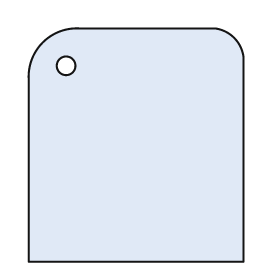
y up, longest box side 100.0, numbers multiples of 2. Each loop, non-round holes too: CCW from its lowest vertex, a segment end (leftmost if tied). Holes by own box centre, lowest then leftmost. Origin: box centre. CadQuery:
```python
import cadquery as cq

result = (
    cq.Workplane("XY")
    .moveTo(-46.0, -50.0)
    .lineTo(46.0, -50.0)
    .lineTo(46.0, 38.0)
    .threePointArc((42.0, 46.0), (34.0, 50.0))
    .lineTo(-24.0, 50.0)
    .threePointArc((-40.0, 44.0), (-46.0, 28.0))
    .close()
    .moveTo(-30.0, 34.0)
    .circle(4.0)
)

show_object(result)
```